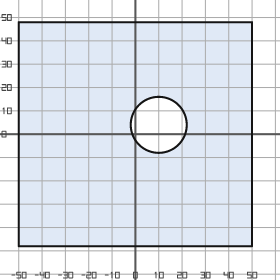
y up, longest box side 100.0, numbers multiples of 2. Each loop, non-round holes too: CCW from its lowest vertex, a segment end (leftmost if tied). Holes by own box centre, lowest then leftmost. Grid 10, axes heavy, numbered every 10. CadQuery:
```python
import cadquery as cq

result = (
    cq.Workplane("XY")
    .moveTo(-50.0, -48.0)
    .lineTo(50.0, -48.0)
    .lineTo(50.0, 48.0)
    .lineTo(-50.0, 48.0)
    .close()
    .moveTo(10.0, 4.0)
    .circle(12.0)
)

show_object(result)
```